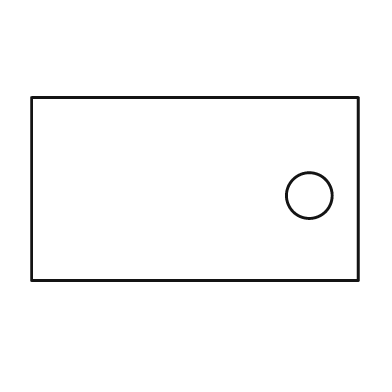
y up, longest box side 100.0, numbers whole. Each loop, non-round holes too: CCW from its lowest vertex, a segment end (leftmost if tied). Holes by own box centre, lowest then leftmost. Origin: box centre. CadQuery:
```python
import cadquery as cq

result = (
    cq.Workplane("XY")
    .moveTo(-50.0, -28.0)
    .lineTo(50.0, -28.0)
    .lineTo(50.0, 28.0)
    .lineTo(-50.0, 28.0)
    .close()
    .moveTo(35.0, -2.0)
    .circle(7.0)
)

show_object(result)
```